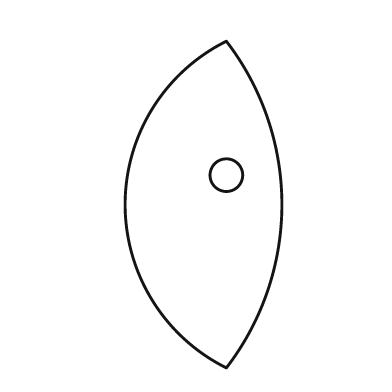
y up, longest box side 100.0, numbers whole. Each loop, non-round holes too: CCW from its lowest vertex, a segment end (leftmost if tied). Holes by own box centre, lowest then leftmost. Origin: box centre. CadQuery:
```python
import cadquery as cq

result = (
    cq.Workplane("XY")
    .moveTo(7.0, -50.0)
    .threePointArc((24.0, 0.0), (7.0, 50.0))
    .threePointArc((-24.0, 0.0), (7.0, -50.0))
    .close()
    .moveTo(7.0, 9.0)
    .circle(5.0)
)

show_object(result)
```